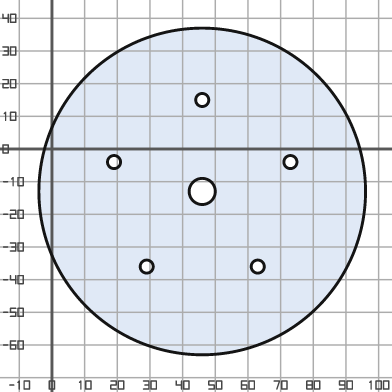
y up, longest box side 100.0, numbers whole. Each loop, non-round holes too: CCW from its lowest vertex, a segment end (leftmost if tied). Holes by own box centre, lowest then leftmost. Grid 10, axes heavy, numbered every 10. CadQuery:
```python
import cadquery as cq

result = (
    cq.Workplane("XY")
    .moveTo(46.0, -13.0)
    .circle(50.0)
    .moveTo(29.0, -36.0)
    .circle(2.0)
    .moveTo(63.0, -36.0)
    .circle(2.0)
    .moveTo(46.0, -13.0)
    .circle(4.0)
    .moveTo(19.0, -4.0)
    .circle(2.0)
    .moveTo(73.0, -4.0)
    .circle(2.0)
    .moveTo(46.0, 15.0)
    .circle(2.0)
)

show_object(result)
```